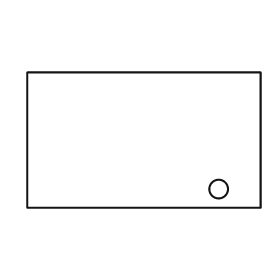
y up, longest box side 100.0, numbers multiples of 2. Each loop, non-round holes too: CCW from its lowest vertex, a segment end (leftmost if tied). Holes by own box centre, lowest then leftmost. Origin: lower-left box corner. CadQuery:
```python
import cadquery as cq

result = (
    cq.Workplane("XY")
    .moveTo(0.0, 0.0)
    .lineTo(100.0, 0.0)
    .lineTo(100.0, 58.0)
    .lineTo(0.0, 58.0)
    .close()
    .moveTo(82.0, 8.0)
    .circle(4.0)
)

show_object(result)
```